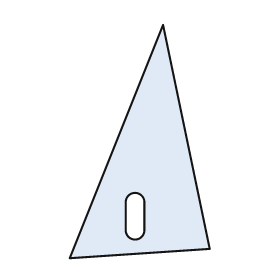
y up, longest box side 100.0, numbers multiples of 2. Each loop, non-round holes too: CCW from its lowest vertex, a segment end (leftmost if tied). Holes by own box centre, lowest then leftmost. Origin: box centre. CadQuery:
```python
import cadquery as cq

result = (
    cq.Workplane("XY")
    .moveTo(-30.0, -50.0)
    .lineTo(30.0, -46.0)
    .lineTo(10.0, 50.0)
    .close()
    .moveTo(-6.0, -38.0)
    .threePointArc((-2.0, -42.0), (2.0, -38.0))
    .lineTo(2.0, -26.0)
    .threePointArc((-2.0, -22.0), (-6.0, -26.0))
    .close()
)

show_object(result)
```